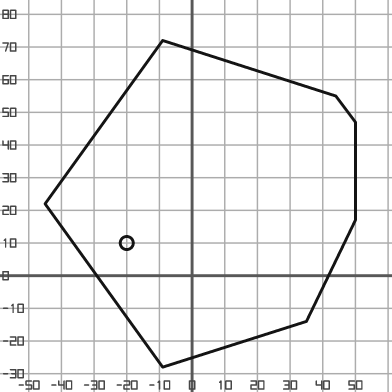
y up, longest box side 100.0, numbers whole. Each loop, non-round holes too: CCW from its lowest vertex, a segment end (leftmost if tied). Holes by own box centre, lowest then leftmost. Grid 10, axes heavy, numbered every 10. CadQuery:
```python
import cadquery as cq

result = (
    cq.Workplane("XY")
    .moveTo(-9.0, -28.0)
    .lineTo(35.0, -14.0)
    .lineTo(50.0, 17.0)
    .lineTo(50.0, 47.0)
    .lineTo(44.0, 55.0)
    .lineTo(-9.0, 72.0)
    .lineTo(-45.0, 22.0)
    .close()
    .moveTo(-20.0, 10.0)
    .circle(2.0)
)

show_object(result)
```